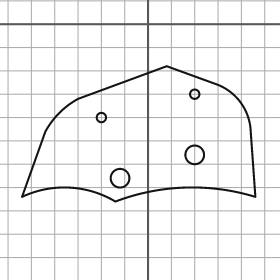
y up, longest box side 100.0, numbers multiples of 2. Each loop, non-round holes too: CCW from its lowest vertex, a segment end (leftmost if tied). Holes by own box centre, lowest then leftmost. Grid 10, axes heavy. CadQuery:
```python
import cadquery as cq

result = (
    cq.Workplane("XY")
    .moveTo(-14.0, -76.0)
    .threePointArc((16.0, -70.0), (46.0, -74.0))
    .lineTo(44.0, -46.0)
    .threePointArc((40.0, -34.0), (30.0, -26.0))
    .lineTo(8.0, -18.0)
    .lineTo(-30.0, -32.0)
    .threePointArc((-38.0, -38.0), (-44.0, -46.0))
    .lineTo(-54.0, -74.0)
    .threePointArc((-34.0, -70.0), (-14.0, -76.0))
    .close()
    .moveTo(-12.0, -66.0)
    .circle(4.0)
    .moveTo(20.0, -56.0)
    .circle(4.0)
    .moveTo(-20.0, -40.0)
    .circle(2.0)
    .moveTo(20.0, -30.0)
    .circle(2.0)
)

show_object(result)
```